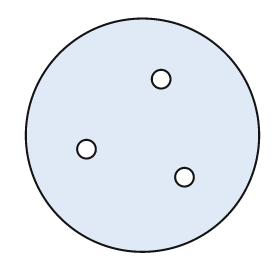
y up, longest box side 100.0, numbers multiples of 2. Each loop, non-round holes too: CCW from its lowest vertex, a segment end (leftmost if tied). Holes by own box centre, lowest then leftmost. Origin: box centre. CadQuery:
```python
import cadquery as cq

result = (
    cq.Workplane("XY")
    .moveTo(0.0, 0.0)
    .circle(50.0)
    .moveTo(18.0, -18.0)
    .circle(4.0)
    .moveTo(-24.0, -6.0)
    .circle(4.0)
    .moveTo(8.0, 24.0)
    .circle(4.0)
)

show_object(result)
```